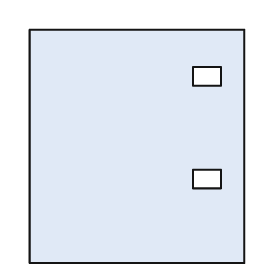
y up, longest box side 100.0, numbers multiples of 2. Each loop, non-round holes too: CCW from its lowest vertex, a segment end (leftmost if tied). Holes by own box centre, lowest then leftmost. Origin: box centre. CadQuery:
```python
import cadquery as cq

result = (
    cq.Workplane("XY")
    .moveTo(-46.0, -50.0)
    .lineTo(46.0, -50.0)
    .lineTo(46.0, 50.0)
    .lineTo(-46.0, 50.0)
    .close()
    .moveTo(24.0, -18.0)
    .lineTo(36.0, -18.0)
    .lineTo(36.0, -10.0)
    .lineTo(24.0, -10.0)
    .close()
    .moveTo(24.0, 26.0)
    .lineTo(36.0, 26.0)
    .lineTo(36.0, 34.0)
    .lineTo(24.0, 34.0)
    .close()
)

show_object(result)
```